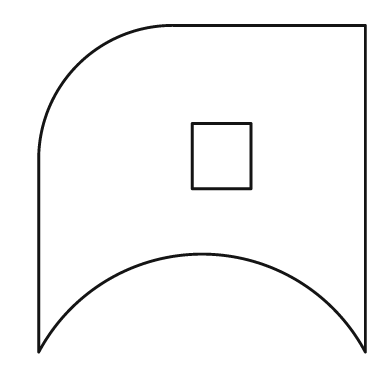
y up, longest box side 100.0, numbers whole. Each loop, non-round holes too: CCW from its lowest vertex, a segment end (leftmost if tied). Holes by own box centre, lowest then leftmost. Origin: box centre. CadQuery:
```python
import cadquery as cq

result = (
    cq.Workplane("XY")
    .moveTo(-50.0, -50.0)
    .threePointArc((0.0, -20.0), (50.0, -50.0))
    .lineTo(50.0, 50.0)
    .lineTo(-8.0, 50.0)
    .threePointArc((-38.0, 38.0), (-50.0, 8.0))
    .close()
    .moveTo(-3.0, 0.0)
    .lineTo(15.0, 0.0)
    .lineTo(15.0, 20.0)
    .lineTo(-3.0, 20.0)
    .close()
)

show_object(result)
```